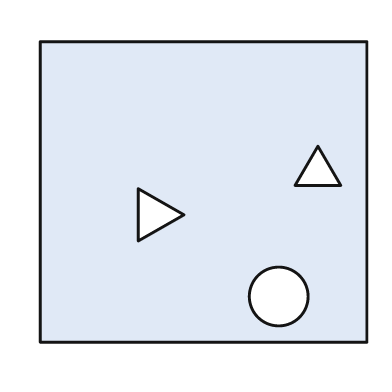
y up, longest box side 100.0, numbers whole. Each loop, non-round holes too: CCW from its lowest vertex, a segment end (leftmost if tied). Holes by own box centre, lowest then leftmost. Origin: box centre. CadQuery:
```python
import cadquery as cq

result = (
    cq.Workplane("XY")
    .moveTo(-50.0, -46.0)
    .lineTo(50.0, -46.0)
    .lineTo(50.0, 46.0)
    .lineTo(-50.0, 46.0)
    .close()
    .moveTo(23.0, -32.0)
    .circle(9.0)
    .moveTo(-20.0, -15.0)
    .lineTo(-6.0, -7.0)
    .lineTo(-20.0, 1.0)
    .close()
    .moveTo(28.0, 2.0)
    .lineTo(42.0, 2.0)
    .lineTo(35.0, 14.0)
    .close()
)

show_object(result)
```